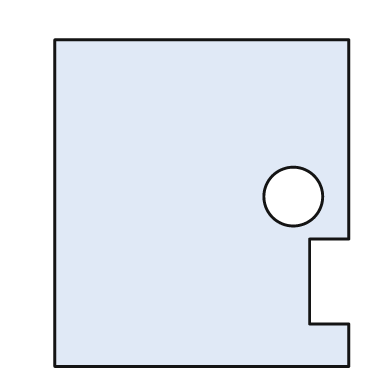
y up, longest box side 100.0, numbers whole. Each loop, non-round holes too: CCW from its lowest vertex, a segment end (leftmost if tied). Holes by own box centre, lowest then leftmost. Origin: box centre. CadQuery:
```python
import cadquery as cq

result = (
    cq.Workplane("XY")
    .moveTo(-45.0, -50.0)
    .lineTo(45.0, -50.0)
    .lineTo(45.0, -37.0)
    .lineTo(33.0, -37.0)
    .lineTo(33.0, -11.0)
    .lineTo(45.0, -11.0)
    .lineTo(45.0, 50.0)
    .lineTo(-45.0, 50.0)
    .close()
    .moveTo(28.0, 2.0)
    .circle(9.0)
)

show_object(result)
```